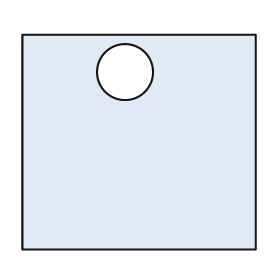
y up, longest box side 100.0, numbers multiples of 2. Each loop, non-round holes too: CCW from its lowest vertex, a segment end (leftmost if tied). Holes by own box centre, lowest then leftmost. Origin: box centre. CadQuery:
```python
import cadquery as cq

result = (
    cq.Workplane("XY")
    .moveTo(-50.0, -46.0)
    .lineTo(50.0, -46.0)
    .lineTo(50.0, 46.0)
    .lineTo(-50.0, 46.0)
    .close()
    .moveTo(-6.0, 30.0)
    .circle(12.0)
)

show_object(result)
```